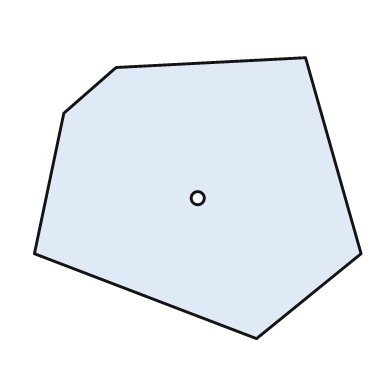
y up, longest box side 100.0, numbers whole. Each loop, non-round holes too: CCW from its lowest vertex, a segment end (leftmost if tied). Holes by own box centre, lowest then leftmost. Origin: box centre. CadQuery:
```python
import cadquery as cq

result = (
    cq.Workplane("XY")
    .moveTo(18.0, -43.0)
    .lineTo(50.0, -17.0)
    .lineTo(33.0, 43.0)
    .lineTo(-25.0, 40.0)
    .lineTo(-41.0, 26.0)
    .lineTo(-50.0, -17.0)
    .close()
    .moveTo(0.0, 0.0)
    .circle(2.0)
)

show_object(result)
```